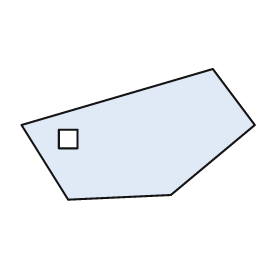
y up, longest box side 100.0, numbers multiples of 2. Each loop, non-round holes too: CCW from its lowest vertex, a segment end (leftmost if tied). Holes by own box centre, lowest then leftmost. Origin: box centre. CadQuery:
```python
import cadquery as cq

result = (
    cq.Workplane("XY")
    .moveTo(-30.0, -28.0)
    .lineTo(14.0, -26.0)
    .lineTo(50.0, 4.0)
    .lineTo(32.0, 28.0)
    .lineTo(-50.0, 4.0)
    .close()
    .moveTo(-34.0, -6.0)
    .lineTo(-26.0, -6.0)
    .lineTo(-26.0, 2.0)
    .lineTo(-34.0, 2.0)
    .close()
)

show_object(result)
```